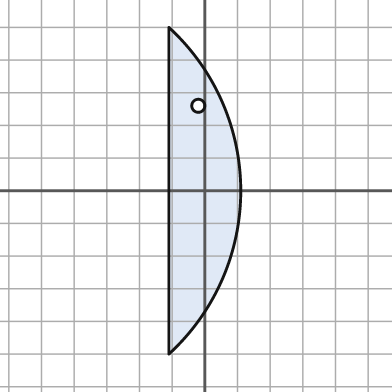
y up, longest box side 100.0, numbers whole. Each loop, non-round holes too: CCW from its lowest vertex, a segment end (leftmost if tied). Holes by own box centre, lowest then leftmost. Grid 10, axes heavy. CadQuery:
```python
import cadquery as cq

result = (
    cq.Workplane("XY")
    .moveTo(-11.0, -50.0)
    .threePointArc((11.0, 0.0), (-11.0, 50.0))
    .close()
    .moveTo(-2.0, 26.0)
    .circle(2.0)
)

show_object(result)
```